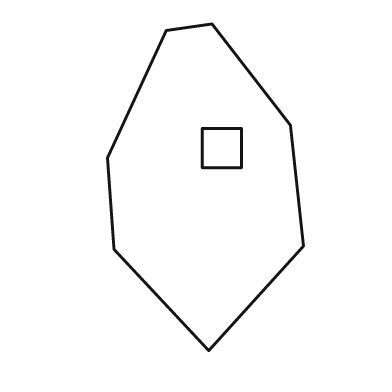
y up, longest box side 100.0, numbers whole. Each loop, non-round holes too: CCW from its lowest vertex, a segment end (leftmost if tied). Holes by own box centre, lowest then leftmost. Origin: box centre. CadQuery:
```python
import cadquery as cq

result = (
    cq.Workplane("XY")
    .moveTo(1.0, -50.0)
    .lineTo(30.0, -18.0)
    .lineTo(26.0, 19.0)
    .lineTo(2.0, 50.0)
    .lineTo(-12.0, 48.0)
    .lineTo(-30.0, 9.0)
    .lineTo(-28.0, -19.0)
    .close()
    .moveTo(-1.0, 6.0)
    .lineTo(11.0, 6.0)
    .lineTo(11.0, 18.0)
    .lineTo(-1.0, 18.0)
    .close()
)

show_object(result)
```